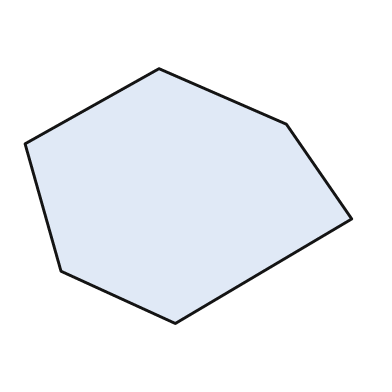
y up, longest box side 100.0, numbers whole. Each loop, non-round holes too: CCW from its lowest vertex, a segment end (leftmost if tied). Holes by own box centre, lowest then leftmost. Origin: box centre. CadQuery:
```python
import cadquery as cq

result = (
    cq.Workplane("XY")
    .moveTo(-4.0, -39.0)
    .lineTo(50.0, -7.0)
    .lineTo(30.0, 22.0)
    .lineTo(-9.0, 39.0)
    .lineTo(-50.0, 16.0)
    .lineTo(-39.0, -23.0)
    .close()
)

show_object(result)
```